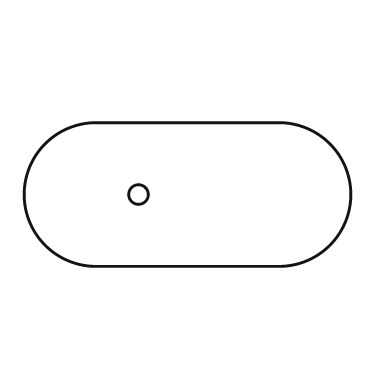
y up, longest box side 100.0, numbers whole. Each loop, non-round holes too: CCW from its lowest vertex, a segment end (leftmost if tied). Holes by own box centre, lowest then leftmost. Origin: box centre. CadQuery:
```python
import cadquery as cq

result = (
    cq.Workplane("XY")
    .moveTo(-28.0, -22.0)
    .lineTo(28.0, -22.0)
    .threePointArc((50.0, 0.0), (28.0, 22.0))
    .lineTo(-28.0, 22.0)
    .threePointArc((-50.0, 0.0), (-28.0, -22.0))
    .close()
    .moveTo(-15.0, 0.0)
    .circle(3.0)
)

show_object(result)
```